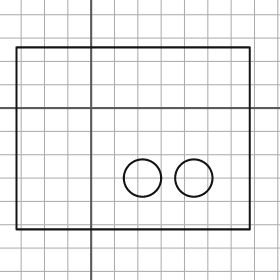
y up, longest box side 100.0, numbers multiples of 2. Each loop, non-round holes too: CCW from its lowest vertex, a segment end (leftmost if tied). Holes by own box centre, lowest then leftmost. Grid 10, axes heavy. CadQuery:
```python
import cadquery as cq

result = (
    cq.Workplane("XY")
    .moveTo(-32.0, -52.0)
    .lineTo(68.0, -52.0)
    .lineTo(68.0, 26.0)
    .lineTo(-32.0, 26.0)
    .close()
    .moveTo(22.0, -30.0)
    .circle(8.0)
    .moveTo(44.0, -30.0)
    .circle(8.0)
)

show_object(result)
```